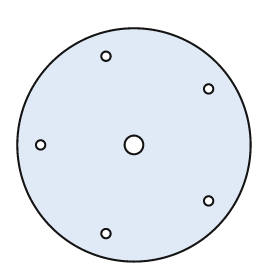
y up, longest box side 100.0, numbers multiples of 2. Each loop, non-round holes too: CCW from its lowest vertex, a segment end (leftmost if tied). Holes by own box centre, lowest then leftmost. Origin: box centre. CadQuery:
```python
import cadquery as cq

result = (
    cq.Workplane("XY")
    .moveTo(0.0, 0.0)
    .circle(50.0)
    .moveTo(-12.0, -38.0)
    .circle(2.0)
    .moveTo(32.0, -24.0)
    .circle(2.0)
    .moveTo(-40.0, 0.0)
    .circle(2.0)
    .moveTo(0.0, 0.0)
    .circle(4.0)
    .moveTo(32.0, 24.0)
    .circle(2.0)
    .moveTo(-12.0, 38.0)
    .circle(2.0)
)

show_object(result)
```